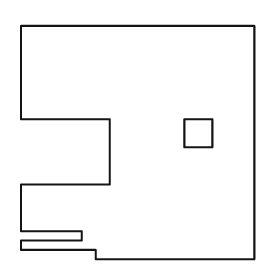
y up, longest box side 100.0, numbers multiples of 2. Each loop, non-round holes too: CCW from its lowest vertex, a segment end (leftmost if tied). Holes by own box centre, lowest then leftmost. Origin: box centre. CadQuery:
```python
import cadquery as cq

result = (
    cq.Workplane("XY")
    .moveTo(-18.0, -50.0)
    .lineTo(50.0, -50.0)
    .lineTo(50.0, 50.0)
    .lineTo(-50.0, 50.0)
    .lineTo(-50.0, 10.0)
    .lineTo(-12.0, 10.0)
    .lineTo(-12.0, -18.0)
    .lineTo(-50.0, -18.0)
    .lineTo(-50.0, -38.0)
    .lineTo(-24.0, -38.0)
    .lineTo(-24.0, -42.0)
    .lineTo(-50.0, -42.0)
    .lineTo(-50.0, -46.0)
    .lineTo(-18.0, -46.0)
    .close()
    .moveTo(20.0, -2.0)
    .lineTo(32.0, -2.0)
    .lineTo(32.0, 10.0)
    .lineTo(20.0, 10.0)
    .close()
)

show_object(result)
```